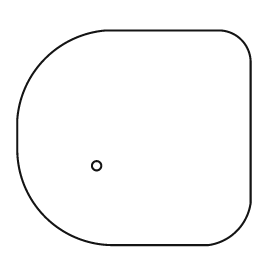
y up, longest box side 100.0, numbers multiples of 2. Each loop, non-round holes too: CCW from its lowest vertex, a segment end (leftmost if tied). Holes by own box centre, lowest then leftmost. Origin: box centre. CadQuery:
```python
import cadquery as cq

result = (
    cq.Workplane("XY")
    .moveTo(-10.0, -46.0)
    .lineTo(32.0, -46.0)
    .threePointArc((44.0, -40.0), (50.0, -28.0))
    .lineTo(50.0, 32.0)
    .threePointArc((46.0, 42.0), (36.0, 46.0))
    .lineTo(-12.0, 46.0)
    .threePointArc((-38.0, 34.0), (-50.0, 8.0))
    .lineTo(-50.0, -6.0)
    .threePointArc((-38.0, -34.0), (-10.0, -46.0))
    .close()
    .moveTo(-16.0, -12.0)
    .circle(2.0)
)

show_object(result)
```